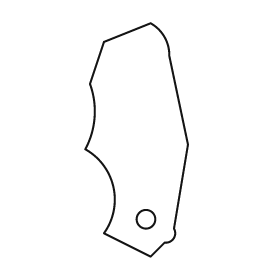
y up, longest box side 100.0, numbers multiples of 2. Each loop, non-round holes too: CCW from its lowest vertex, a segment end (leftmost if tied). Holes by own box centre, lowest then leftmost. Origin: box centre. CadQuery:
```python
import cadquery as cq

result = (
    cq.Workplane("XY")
    .moveTo(6.0, -50.0)
    .lineTo(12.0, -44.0)
    .threePointArc((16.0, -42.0), (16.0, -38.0))
    .lineTo(22.0, -2.0)
    .lineTo(14.0, 36.0)
    .threePointArc((12.0, 44.0), (6.0, 50.0))
    .lineTo(-14.0, 42.0)
    .lineTo(-20.0, 24.0)
    .threePointArc((-18.0, 10.0), (-22.0, -4.0))
    .threePointArc((-10.0, -20.0), (-14.0, -40.0))
    .close()
    .moveTo(4.0, -34.0)
    .circle(4.0)
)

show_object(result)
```